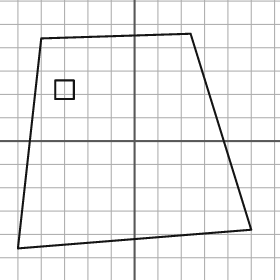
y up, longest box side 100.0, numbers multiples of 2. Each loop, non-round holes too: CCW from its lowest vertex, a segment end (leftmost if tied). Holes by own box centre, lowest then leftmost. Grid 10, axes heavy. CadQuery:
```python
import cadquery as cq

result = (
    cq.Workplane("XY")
    .moveTo(-50.0, -46.0)
    .lineTo(50.0, -38.0)
    .lineTo(24.0, 46.0)
    .lineTo(-40.0, 44.0)
    .close()
    .moveTo(-34.0, 18.0)
    .lineTo(-26.0, 18.0)
    .lineTo(-26.0, 26.0)
    .lineTo(-34.0, 26.0)
    .close()
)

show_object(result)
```